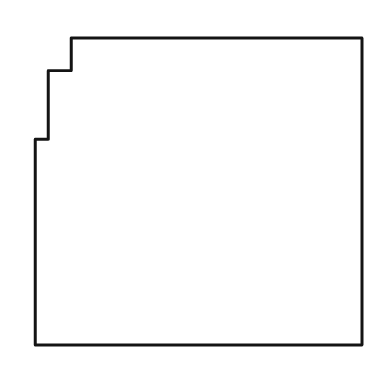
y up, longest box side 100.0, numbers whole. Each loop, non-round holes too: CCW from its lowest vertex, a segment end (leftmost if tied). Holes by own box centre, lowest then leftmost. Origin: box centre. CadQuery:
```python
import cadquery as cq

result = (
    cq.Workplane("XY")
    .moveTo(-50.0, -47.0)
    .lineTo(50.0, -47.0)
    .lineTo(50.0, 47.0)
    .lineTo(-39.0, 47.0)
    .lineTo(-39.0, 37.0)
    .lineTo(-46.0, 37.0)
    .lineTo(-46.0, 16.0)
    .lineTo(-50.0, 16.0)
    .close()
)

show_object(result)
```